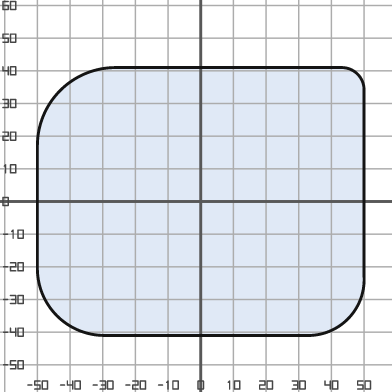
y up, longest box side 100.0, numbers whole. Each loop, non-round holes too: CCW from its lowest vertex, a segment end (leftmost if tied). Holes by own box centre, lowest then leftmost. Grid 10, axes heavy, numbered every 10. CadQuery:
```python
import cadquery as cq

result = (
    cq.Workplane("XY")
    .moveTo(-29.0, -41.0)
    .lineTo(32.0, -41.0)
    .threePointArc((45.0, -36.0), (50.0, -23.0))
    .lineTo(50.0, 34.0)
    .threePointArc((48.0, 39.0), (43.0, 41.0))
    .lineTo(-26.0, 41.0)
    .threePointArc((-43.0, 34.0), (-50.0, 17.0))
    .lineTo(-50.0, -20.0)
    .threePointArc((-44.0, -35.0), (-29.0, -41.0))
    .close()
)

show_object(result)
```